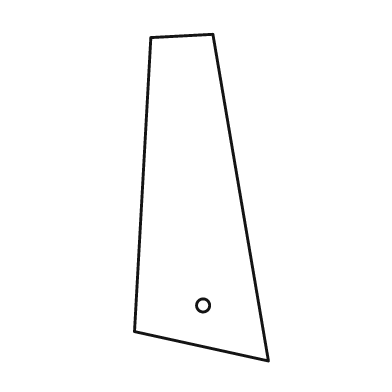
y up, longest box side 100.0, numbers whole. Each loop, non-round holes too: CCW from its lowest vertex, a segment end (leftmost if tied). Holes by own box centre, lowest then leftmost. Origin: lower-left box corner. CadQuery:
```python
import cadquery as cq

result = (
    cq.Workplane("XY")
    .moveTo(41.0, 0.0)
    .lineTo(24.0, 100.0)
    .lineTo(5.0, 99.0)
    .lineTo(0.0, 9.0)
    .close()
    .moveTo(21.0, 17.0)
    .circle(2.0)
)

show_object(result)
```